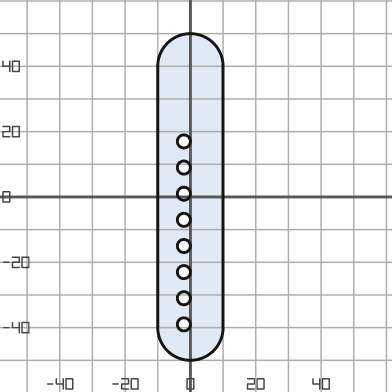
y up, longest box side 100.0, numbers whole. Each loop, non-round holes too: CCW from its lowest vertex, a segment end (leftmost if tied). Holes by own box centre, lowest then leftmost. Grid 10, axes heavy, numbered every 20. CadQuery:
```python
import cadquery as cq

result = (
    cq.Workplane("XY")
    .moveTo(-10.0, -40.0)
    .threePointArc((0.0, -50.0), (10.0, -40.0))
    .lineTo(10.0, 40.0)
    .threePointArc((0.0, 50.0), (-10.0, 40.0))
    .close()
    .moveTo(-2.0, -39.0)
    .circle(2.0)
    .moveTo(-2.0, -31.0)
    .circle(2.0)
    .moveTo(-2.0, -23.0)
    .circle(2.0)
    .moveTo(-2.0, -15.0)
    .circle(2.0)
    .moveTo(-2.0, -7.0)
    .circle(2.0)
    .moveTo(-2.0, 1.0)
    .circle(2.0)
    .moveTo(-2.0, 9.0)
    .circle(2.0)
    .moveTo(-2.0, 17.0)
    .circle(2.0)
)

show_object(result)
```